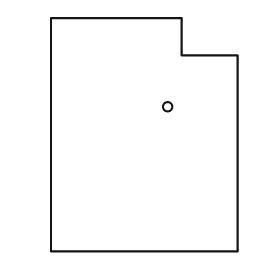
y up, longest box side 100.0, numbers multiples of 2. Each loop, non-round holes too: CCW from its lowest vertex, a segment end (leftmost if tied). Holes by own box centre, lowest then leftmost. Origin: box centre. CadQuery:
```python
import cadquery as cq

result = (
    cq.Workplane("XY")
    .moveTo(-40.0, -50.0)
    .lineTo(40.0, -50.0)
    .lineTo(40.0, 34.0)
    .lineTo(16.0, 34.0)
    .lineTo(16.0, 50.0)
    .lineTo(-40.0, 50.0)
    .close()
    .moveTo(10.0, 12.0)
    .circle(2.0)
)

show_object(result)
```